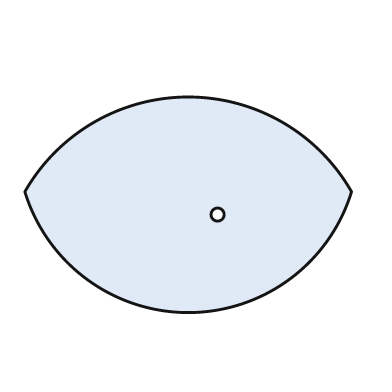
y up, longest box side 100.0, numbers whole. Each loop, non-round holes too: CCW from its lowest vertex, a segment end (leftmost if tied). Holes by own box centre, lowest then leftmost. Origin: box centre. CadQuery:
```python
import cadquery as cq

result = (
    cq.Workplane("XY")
    .moveTo(-50.0, 4.0)
    .threePointArc((0.0, -33.0), (50.0, 4.0))
    .threePointArc((0.0, 33.0), (-50.0, 4.0))
    .close()
    .moveTo(9.0, -3.0)
    .circle(2.0)
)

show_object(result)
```